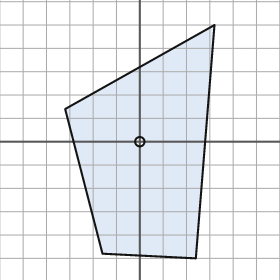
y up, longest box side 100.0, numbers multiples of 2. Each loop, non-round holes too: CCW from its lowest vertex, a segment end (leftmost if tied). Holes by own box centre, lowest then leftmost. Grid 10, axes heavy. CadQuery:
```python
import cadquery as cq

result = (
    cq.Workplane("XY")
    .moveTo(24.0, -50.0)
    .lineTo(32.0, 50.0)
    .lineTo(-32.0, 14.0)
    .lineTo(-16.0, -48.0)
    .close()
    .moveTo(0.0, 0.0)
    .circle(2.0)
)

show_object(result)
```